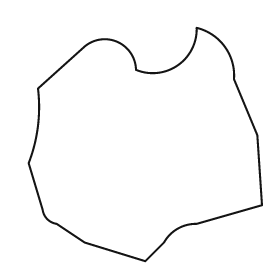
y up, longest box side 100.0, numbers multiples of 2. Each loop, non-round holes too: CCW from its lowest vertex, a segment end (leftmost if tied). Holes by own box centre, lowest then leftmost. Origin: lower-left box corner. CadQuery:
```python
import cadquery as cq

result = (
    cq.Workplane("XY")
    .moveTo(50.0, 0.0)
    .lineTo(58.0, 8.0)
    .threePointArc((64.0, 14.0), (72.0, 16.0))
    .lineTo(100.0, 24.0)
    .lineTo(98.0, 54.0)
    .lineTo(88.0, 78.0)
    .threePointArc((84.0, 92.0), (72.0, 100.0))
    .threePointArc((64.0, 84.0), (46.0, 82.0))
    .threePointArc((38.0, 94.0), (24.0, 92.0))
    .lineTo(4.0, 74.0)
    .threePointArc((4.0, 58.0), (0.0, 42.0))
    .lineTo(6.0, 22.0)
    .threePointArc((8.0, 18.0), (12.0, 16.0))
    .lineTo(24.0, 8.0)
    .close()
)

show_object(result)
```